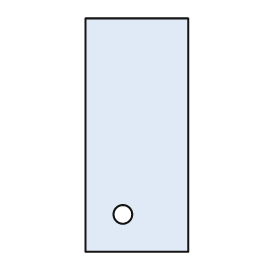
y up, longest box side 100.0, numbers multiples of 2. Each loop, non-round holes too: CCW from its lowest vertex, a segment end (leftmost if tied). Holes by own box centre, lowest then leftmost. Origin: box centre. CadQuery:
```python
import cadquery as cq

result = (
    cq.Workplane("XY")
    .moveTo(-22.0, -50.0)
    .lineTo(22.0, -50.0)
    .lineTo(22.0, 50.0)
    .lineTo(-22.0, 50.0)
    .close()
    .moveTo(-6.0, -34.0)
    .circle(4.0)
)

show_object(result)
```